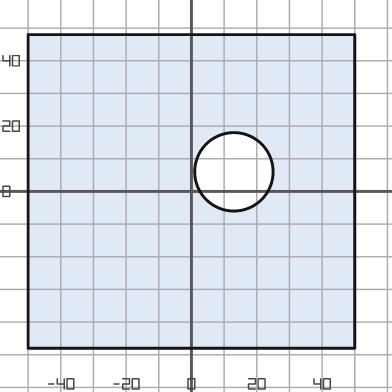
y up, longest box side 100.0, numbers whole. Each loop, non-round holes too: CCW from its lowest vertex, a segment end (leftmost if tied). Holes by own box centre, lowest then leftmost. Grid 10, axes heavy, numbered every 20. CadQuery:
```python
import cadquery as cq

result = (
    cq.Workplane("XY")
    .moveTo(-50.0, -48.0)
    .lineTo(50.0, -48.0)
    .lineTo(50.0, 48.0)
    .lineTo(-50.0, 48.0)
    .close()
    .moveTo(13.0, 6.0)
    .circle(12.0)
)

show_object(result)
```